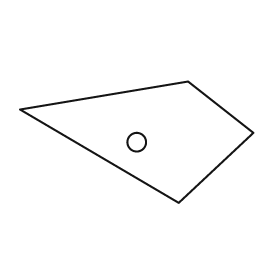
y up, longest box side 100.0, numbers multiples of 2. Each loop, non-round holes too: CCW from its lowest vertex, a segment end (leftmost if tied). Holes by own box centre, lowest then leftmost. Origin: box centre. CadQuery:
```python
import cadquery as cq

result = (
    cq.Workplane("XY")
    .moveTo(18.0, -26.0)
    .lineTo(50.0, 4.0)
    .lineTo(22.0, 26.0)
    .lineTo(-50.0, 14.0)
    .close()
    .moveTo(0.0, 0.0)
    .circle(4.0)
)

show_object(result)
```